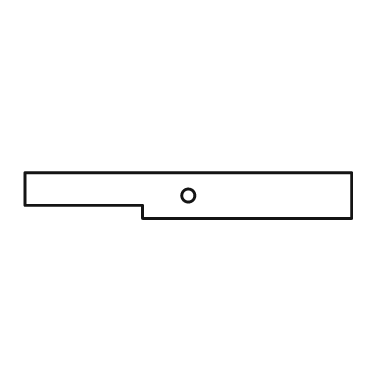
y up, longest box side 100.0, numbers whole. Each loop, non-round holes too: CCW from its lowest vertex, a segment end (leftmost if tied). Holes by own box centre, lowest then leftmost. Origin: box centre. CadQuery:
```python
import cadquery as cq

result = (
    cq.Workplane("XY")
    .moveTo(-14.0, -7.0)
    .lineTo(50.0, -7.0)
    .lineTo(50.0, 7.0)
    .lineTo(-50.0, 7.0)
    .lineTo(-50.0, -3.0)
    .lineTo(-14.0, -3.0)
    .close()
    .moveTo(0.0, 0.0)
    .circle(2.0)
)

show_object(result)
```